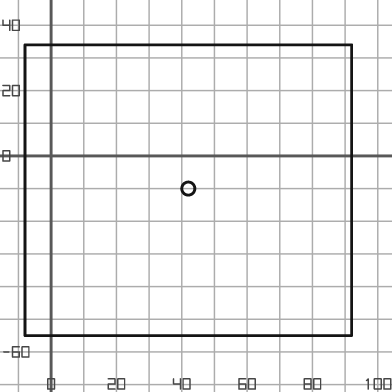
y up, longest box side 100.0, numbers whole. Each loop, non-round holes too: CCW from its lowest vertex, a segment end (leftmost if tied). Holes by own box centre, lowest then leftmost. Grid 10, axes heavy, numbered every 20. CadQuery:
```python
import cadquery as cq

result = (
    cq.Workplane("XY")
    .moveTo(-8.0, -55.0)
    .lineTo(92.0, -55.0)
    .lineTo(92.0, 34.0)
    .lineTo(-8.0, 34.0)
    .close()
    .moveTo(42.0, -10.0)
    .circle(2.0)
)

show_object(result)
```